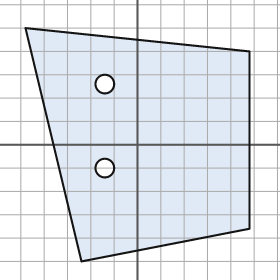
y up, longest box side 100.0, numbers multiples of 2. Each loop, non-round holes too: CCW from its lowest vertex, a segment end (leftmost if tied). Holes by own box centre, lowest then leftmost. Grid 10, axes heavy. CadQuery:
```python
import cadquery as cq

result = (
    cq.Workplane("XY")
    .moveTo(-24.0, -50.0)
    .lineTo(48.0, -36.0)
    .lineTo(48.0, 40.0)
    .lineTo(-48.0, 50.0)
    .close()
    .moveTo(-14.0, -10.0)
    .circle(4.0)
    .moveTo(-14.0, 26.0)
    .circle(4.0)
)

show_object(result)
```